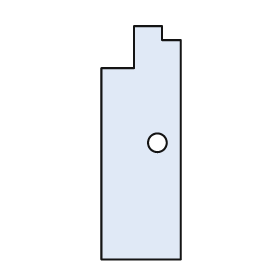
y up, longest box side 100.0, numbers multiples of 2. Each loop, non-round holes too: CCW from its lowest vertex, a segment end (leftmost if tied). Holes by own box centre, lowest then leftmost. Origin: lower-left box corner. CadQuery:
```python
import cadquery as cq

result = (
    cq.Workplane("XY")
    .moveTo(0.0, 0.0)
    .lineTo(34.0, 0.0)
    .lineTo(34.0, 94.0)
    .lineTo(26.0, 94.0)
    .lineTo(26.0, 100.0)
    .lineTo(14.0, 100.0)
    .lineTo(14.0, 82.0)
    .lineTo(0.0, 82.0)
    .close()
    .moveTo(24.0, 50.0)
    .circle(4.0)
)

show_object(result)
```